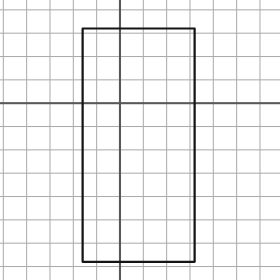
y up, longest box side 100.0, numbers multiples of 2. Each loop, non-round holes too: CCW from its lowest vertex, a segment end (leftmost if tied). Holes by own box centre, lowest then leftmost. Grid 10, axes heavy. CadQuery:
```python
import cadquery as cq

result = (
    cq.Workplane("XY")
    .moveTo(-16.0, -68.0)
    .lineTo(32.0, -68.0)
    .lineTo(32.0, 32.0)
    .lineTo(-16.0, 32.0)
    .close()
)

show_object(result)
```